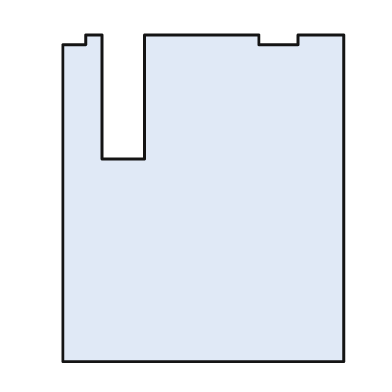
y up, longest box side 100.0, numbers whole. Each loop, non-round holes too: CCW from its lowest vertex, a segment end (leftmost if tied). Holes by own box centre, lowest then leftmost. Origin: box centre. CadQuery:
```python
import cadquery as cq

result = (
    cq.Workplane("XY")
    .moveTo(-43.0, -50.0)
    .lineTo(43.0, -50.0)
    .lineTo(43.0, 50.0)
    .lineTo(29.0, 50.0)
    .lineTo(29.0, 47.0)
    .lineTo(17.0, 47.0)
    .lineTo(17.0, 50.0)
    .lineTo(-18.0, 50.0)
    .lineTo(-18.0, 12.0)
    .lineTo(-31.0, 12.0)
    .lineTo(-31.0, 50.0)
    .lineTo(-36.0, 50.0)
    .lineTo(-36.0, 47.0)
    .lineTo(-43.0, 47.0)
    .close()
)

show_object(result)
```